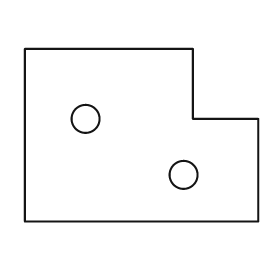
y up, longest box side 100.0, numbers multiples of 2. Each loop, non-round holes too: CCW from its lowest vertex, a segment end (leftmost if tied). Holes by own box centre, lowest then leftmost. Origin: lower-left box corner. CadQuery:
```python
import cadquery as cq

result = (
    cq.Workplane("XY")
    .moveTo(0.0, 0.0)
    .lineTo(100.0, 0.0)
    .lineTo(100.0, 44.0)
    .lineTo(72.0, 44.0)
    .lineTo(72.0, 74.0)
    .lineTo(0.0, 74.0)
    .close()
    .moveTo(68.0, 20.0)
    .circle(6.0)
    .moveTo(26.0, 44.0)
    .circle(6.0)
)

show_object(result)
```